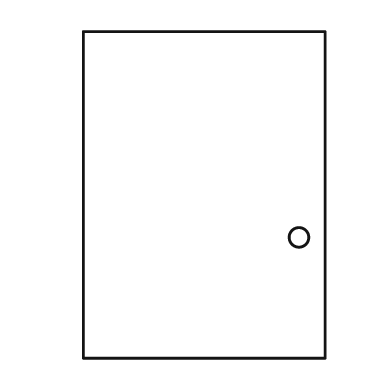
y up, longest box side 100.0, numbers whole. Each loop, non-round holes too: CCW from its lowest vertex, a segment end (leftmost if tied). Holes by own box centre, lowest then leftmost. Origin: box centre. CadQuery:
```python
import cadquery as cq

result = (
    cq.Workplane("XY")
    .moveTo(-37.0, -50.0)
    .lineTo(37.0, -50.0)
    .lineTo(37.0, 50.0)
    .lineTo(-37.0, 50.0)
    .close()
    .moveTo(29.0, -13.0)
    .circle(3.0)
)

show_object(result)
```